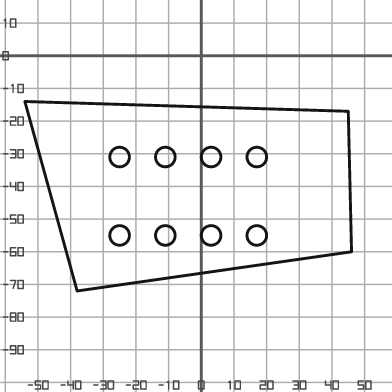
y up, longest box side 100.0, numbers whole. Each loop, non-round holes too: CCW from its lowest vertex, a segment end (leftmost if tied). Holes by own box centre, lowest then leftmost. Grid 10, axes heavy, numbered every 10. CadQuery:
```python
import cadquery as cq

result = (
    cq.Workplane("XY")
    .moveTo(-38.0, -72.0)
    .lineTo(46.0, -60.0)
    .lineTo(45.0, -17.0)
    .lineTo(-54.0, -14.0)
    .close()
    .moveTo(-25.0, -55.0)
    .circle(3.0)
    .moveTo(-11.0, -55.0)
    .circle(3.0)
    .moveTo(3.0, -55.0)
    .circle(3.0)
    .moveTo(17.0, -55.0)
    .circle(3.0)
    .moveTo(-25.0, -31.0)
    .circle(3.0)
    .moveTo(-11.0, -31.0)
    .circle(3.0)
    .moveTo(3.0, -31.0)
    .circle(3.0)
    .moveTo(17.0, -31.0)
    .circle(3.0)
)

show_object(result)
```